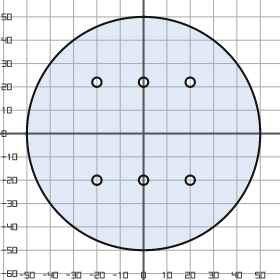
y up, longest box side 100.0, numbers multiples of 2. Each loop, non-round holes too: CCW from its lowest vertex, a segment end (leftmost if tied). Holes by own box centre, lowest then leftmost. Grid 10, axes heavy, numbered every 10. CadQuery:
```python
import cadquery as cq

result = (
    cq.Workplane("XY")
    .moveTo(0.0, 0.0)
    .circle(50.0)
    .moveTo(-20.0, -20.0)
    .circle(2.0)
    .moveTo(0.0, -20.0)
    .circle(2.0)
    .moveTo(20.0, -20.0)
    .circle(2.0)
    .moveTo(-20.0, 22.0)
    .circle(2.0)
    .moveTo(0.0, 22.0)
    .circle(2.0)
    .moveTo(20.0, 22.0)
    .circle(2.0)
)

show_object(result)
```